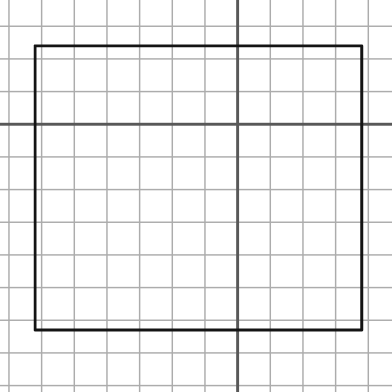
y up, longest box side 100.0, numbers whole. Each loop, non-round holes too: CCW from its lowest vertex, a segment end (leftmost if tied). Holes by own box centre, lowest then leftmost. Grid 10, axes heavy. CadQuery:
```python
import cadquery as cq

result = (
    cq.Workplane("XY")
    .moveTo(-62.0, -63.0)
    .lineTo(38.0, -63.0)
    .lineTo(38.0, 24.0)
    .lineTo(-62.0, 24.0)
    .close()
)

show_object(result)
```